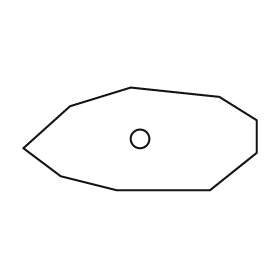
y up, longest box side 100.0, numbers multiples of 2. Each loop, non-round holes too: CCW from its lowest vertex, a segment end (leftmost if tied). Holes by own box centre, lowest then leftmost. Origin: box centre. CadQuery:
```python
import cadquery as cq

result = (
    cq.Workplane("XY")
    .moveTo(-10.0, -22.0)
    .lineTo(30.0, -22.0)
    .lineTo(50.0, -6.0)
    .lineTo(50.0, 8.0)
    .lineTo(34.0, 18.0)
    .lineTo(-4.0, 22.0)
    .lineTo(-30.0, 14.0)
    .lineTo(-50.0, -4.0)
    .lineTo(-34.0, -16.0)
    .close()
    .moveTo(0.0, 0.0)
    .circle(4.0)
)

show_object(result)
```